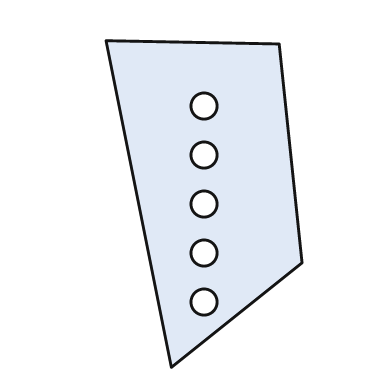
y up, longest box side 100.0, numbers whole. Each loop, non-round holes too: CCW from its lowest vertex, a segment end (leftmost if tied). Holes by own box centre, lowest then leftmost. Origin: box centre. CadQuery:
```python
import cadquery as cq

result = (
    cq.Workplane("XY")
    .moveTo(-10.0, -50.0)
    .lineTo(30.0, -18.0)
    .lineTo(23.0, 49.0)
    .lineTo(-30.0, 50.0)
    .close()
    .moveTo(0.0, -30.0)
    .circle(4.0)
    .moveTo(0.0, -15.0)
    .circle(4.0)
    .moveTo(0.0, 0.0)
    .circle(4.0)
    .moveTo(0.0, 15.0)
    .circle(4.0)
    .moveTo(0.0, 30.0)
    .circle(4.0)
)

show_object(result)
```